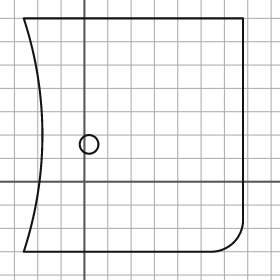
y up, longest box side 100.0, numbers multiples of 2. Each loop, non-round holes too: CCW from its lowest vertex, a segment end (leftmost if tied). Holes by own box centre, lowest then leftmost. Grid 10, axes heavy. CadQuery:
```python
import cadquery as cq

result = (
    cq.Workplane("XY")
    .moveTo(-26.0, -30.0)
    .lineTo(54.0, -30.0)
    .threePointArc((64.0, -26.0), (68.0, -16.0))
    .lineTo(68.0, 70.0)
    .lineTo(-26.0, 70.0)
    .threePointArc((-18.0, 20.0), (-26.0, -30.0))
    .close()
    .moveTo(2.0, 16.0)
    .circle(4.0)
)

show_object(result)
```